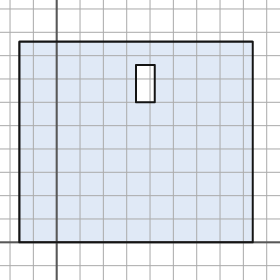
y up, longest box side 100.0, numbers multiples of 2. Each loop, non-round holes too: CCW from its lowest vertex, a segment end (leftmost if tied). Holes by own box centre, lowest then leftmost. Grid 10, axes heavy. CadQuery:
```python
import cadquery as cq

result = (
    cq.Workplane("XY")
    .moveTo(-16.0, 0.0)
    .lineTo(84.0, 0.0)
    .lineTo(84.0, 86.0)
    .lineTo(-16.0, 86.0)
    .close()
    .moveTo(34.0, 60.0)
    .lineTo(42.0, 60.0)
    .lineTo(42.0, 76.0)
    .lineTo(34.0, 76.0)
    .close()
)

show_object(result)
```